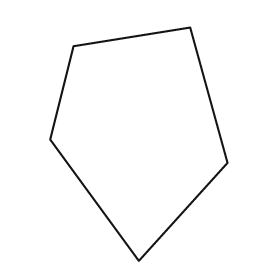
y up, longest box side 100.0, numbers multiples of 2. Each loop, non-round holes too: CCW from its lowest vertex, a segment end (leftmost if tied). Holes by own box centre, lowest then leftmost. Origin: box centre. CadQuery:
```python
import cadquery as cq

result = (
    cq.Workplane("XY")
    .moveTo(0.0, -50.0)
    .lineTo(38.0, -8.0)
    .lineTo(22.0, 50.0)
    .lineTo(-28.0, 42.0)
    .lineTo(-38.0, 2.0)
    .close()
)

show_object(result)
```